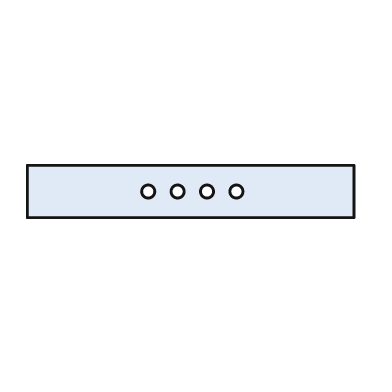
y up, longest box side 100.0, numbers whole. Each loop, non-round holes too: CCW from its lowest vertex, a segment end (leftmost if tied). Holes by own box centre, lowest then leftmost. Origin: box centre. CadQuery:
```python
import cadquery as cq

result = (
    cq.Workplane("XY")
    .moveTo(-50.0, -8.0)
    .lineTo(50.0, -8.0)
    .lineTo(50.0, 8.0)
    .lineTo(-50.0, 8.0)
    .close()
    .moveTo(-13.0, 0.0)
    .circle(2.0)
    .moveTo(-4.0, 0.0)
    .circle(2.0)
    .moveTo(5.0, 0.0)
    .circle(2.0)
    .moveTo(14.0, 0.0)
    .circle(2.0)
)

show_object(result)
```